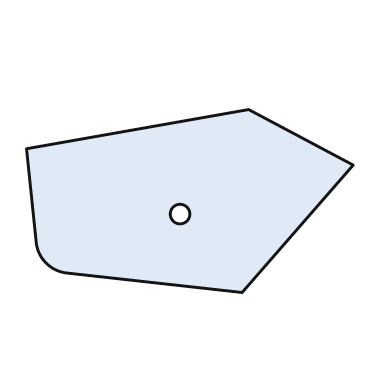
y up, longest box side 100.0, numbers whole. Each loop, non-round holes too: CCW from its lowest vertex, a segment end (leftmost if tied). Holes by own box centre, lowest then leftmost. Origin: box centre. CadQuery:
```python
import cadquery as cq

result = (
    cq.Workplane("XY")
    .moveTo(16.0, -28.0)
    .lineTo(50.0, 11.0)
    .lineTo(18.0, 28.0)
    .lineTo(-50.0, 16.0)
    .lineTo(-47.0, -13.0)
    .threePointArc((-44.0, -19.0), (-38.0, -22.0))
    .close()
    .moveTo(-3.0, -4.0)
    .circle(3.0)
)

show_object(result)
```